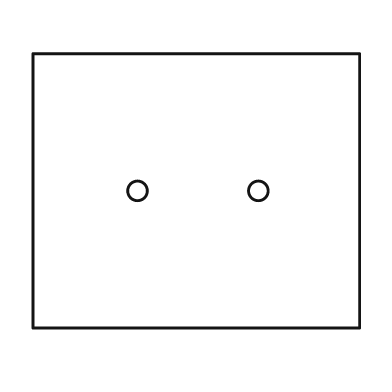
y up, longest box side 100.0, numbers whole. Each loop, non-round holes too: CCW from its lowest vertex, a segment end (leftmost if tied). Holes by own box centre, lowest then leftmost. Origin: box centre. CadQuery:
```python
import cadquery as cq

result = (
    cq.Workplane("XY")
    .moveTo(-50.0, -42.0)
    .lineTo(50.0, -42.0)
    .lineTo(50.0, 42.0)
    .lineTo(-50.0, 42.0)
    .close()
    .moveTo(-18.0, 0.0)
    .circle(3.0)
    .moveTo(19.0, 0.0)
    .circle(3.0)
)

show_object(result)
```